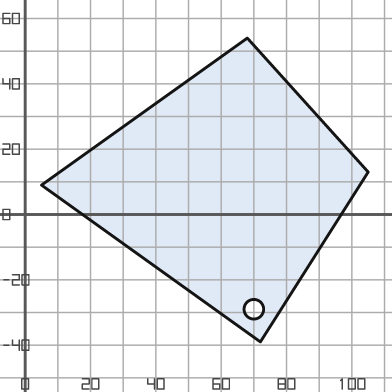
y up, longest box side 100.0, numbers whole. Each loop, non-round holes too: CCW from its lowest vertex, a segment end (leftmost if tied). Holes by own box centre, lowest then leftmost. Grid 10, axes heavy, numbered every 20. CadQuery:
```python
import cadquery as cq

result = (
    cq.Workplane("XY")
    .moveTo(72.0, -39.0)
    .lineTo(105.0, 13.0)
    .lineTo(68.0, 54.0)
    .lineTo(5.0, 9.0)
    .close()
    .moveTo(70.0, -29.0)
    .circle(3.0)
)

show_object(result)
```